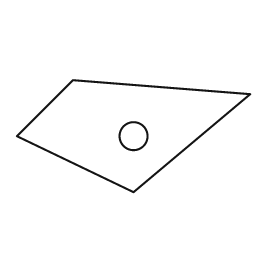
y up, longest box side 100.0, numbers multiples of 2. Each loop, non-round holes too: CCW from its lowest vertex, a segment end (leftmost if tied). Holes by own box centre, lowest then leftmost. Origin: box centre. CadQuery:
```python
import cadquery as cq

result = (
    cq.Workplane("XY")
    .moveTo(0.0, -24.0)
    .lineTo(50.0, 18.0)
    .lineTo(-26.0, 24.0)
    .lineTo(-50.0, 0.0)
    .close()
    .moveTo(0.0, 0.0)
    .circle(6.0)
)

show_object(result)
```